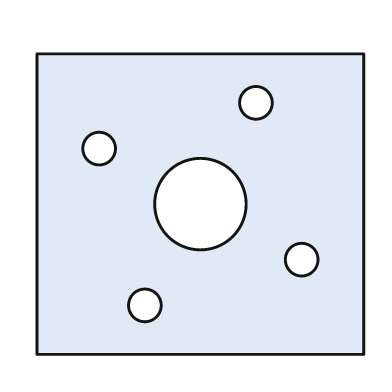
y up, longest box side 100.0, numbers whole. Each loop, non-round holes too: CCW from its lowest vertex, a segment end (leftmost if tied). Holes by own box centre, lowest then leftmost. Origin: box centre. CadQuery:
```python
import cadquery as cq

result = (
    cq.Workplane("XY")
    .moveTo(-50.0, -46.0)
    .lineTo(50.0, -46.0)
    .lineTo(50.0, 46.0)
    .lineTo(-50.0, 46.0)
    .close()
    .moveTo(-17.0, -31.0)
    .circle(5.0)
    .moveTo(31.0, -17.0)
    .circle(5.0)
    .moveTo(0.0, 0.0)
    .circle(14.0)
    .moveTo(-31.0, 17.0)
    .circle(5.0)
    .moveTo(17.0, 31.0)
    .circle(5.0)
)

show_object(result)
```